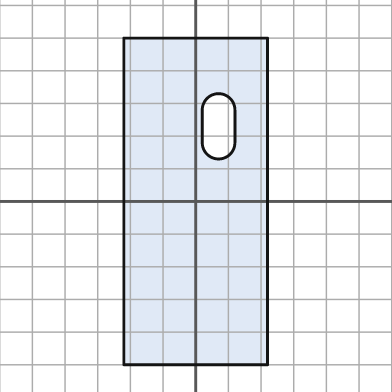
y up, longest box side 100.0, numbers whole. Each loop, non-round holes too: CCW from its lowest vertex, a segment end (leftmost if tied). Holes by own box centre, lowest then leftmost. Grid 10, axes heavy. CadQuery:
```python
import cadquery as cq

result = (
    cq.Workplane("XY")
    .moveTo(-22.0, -50.0)
    .lineTo(22.0, -50.0)
    .lineTo(22.0, 50.0)
    .lineTo(-22.0, 50.0)
    .close()
    .moveTo(2.0, 18.0)
    .threePointArc((7.0, 13.0), (12.0, 18.0))
    .lineTo(12.0, 28.0)
    .threePointArc((7.0, 33.0), (2.0, 28.0))
    .close()
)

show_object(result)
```